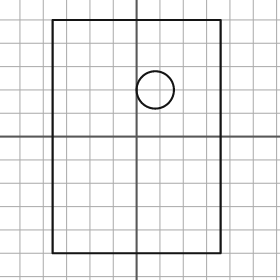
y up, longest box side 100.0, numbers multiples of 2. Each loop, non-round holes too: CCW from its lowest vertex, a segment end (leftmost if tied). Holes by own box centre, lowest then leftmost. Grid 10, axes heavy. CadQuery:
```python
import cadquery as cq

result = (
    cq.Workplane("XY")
    .moveTo(-36.0, -50.0)
    .lineTo(36.0, -50.0)
    .lineTo(36.0, 50.0)
    .lineTo(-36.0, 50.0)
    .close()
    .moveTo(8.0, 20.0)
    .circle(8.0)
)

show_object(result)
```